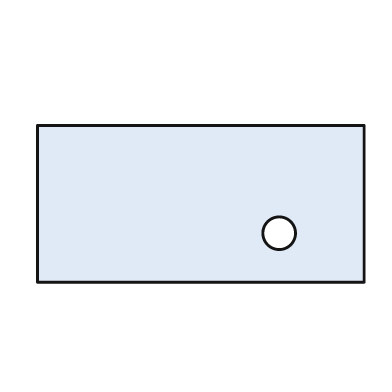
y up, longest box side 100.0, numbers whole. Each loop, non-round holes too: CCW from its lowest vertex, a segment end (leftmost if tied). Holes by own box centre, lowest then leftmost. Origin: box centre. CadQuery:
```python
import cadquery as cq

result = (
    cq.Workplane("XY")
    .moveTo(-50.0, -24.0)
    .lineTo(50.0, -24.0)
    .lineTo(50.0, 24.0)
    .lineTo(-50.0, 24.0)
    .close()
    .moveTo(24.0, -9.0)
    .circle(5.0)
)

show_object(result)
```